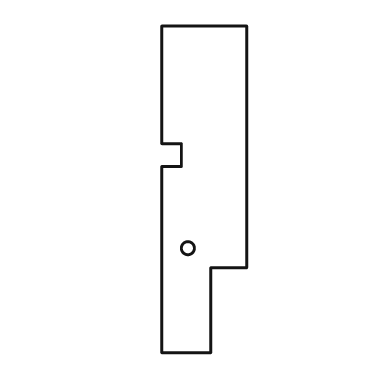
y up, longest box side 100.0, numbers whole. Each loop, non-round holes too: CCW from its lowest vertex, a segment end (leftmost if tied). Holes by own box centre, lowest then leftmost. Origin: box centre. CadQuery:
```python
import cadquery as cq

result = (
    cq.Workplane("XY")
    .moveTo(-13.0, -50.0)
    .lineTo(2.0, -50.0)
    .lineTo(2.0, -24.0)
    .lineTo(13.0, -24.0)
    .lineTo(13.0, 50.0)
    .lineTo(-13.0, 50.0)
    .lineTo(-13.0, 14.0)
    .lineTo(-7.0, 14.0)
    .lineTo(-7.0, 7.0)
    .lineTo(-13.0, 7.0)
    .close()
    .moveTo(-5.0, -18.0)
    .circle(2.0)
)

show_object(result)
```